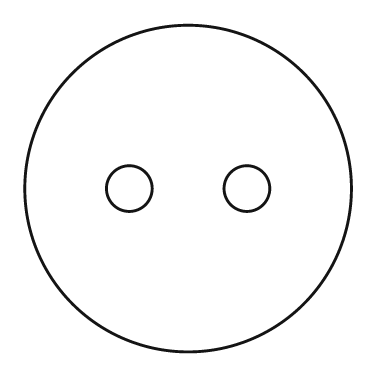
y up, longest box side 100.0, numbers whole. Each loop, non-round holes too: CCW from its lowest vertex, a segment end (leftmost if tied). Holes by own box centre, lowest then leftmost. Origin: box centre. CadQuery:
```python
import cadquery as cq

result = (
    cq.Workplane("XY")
    .moveTo(0.0, 0.0)
    .circle(50.0)
    .moveTo(-18.0, 0.0)
    .circle(7.0)
    .moveTo(18.0, 0.0)
    .circle(7.0)
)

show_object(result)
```